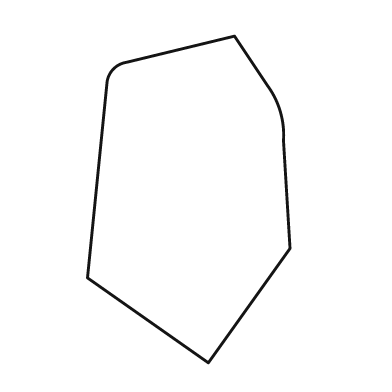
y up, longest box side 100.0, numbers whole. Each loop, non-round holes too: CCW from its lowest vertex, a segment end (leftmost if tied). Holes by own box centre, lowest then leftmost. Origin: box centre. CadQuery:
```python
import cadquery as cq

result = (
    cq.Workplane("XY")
    .moveTo(6.0, -50.0)
    .lineTo(31.0, -15.0)
    .lineTo(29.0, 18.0)
    .threePointArc((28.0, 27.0), (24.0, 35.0))
    .lineTo(14.0, 50.0)
    .lineTo(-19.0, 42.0)
    .threePointArc((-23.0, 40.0), (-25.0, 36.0))
    .lineTo(-31.0, -24.0)
    .close()
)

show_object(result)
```